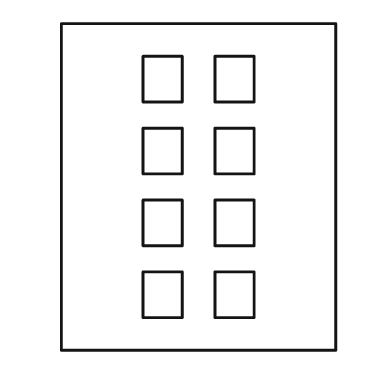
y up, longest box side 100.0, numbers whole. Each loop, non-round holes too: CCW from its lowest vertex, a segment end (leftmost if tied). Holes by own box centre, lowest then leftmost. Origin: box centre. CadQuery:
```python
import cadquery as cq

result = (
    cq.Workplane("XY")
    .moveTo(-42.0, -50.0)
    .lineTo(42.0, -50.0)
    .lineTo(42.0, 50.0)
    .lineTo(-42.0, 50.0)
    .close()
    .moveTo(-17.0, -40.0)
    .lineTo(-5.0, -40.0)
    .lineTo(-5.0, -26.0)
    .lineTo(-17.0, -26.0)
    .close()
    .moveTo(5.0, -40.0)
    .lineTo(17.0, -40.0)
    .lineTo(17.0, -26.0)
    .lineTo(5.0, -26.0)
    .close()
    .moveTo(-17.0, -18.0)
    .lineTo(-5.0, -18.0)
    .lineTo(-5.0, -4.0)
    .lineTo(-17.0, -4.0)
    .close()
    .moveTo(5.0, -18.0)
    .lineTo(17.0, -18.0)
    .lineTo(17.0, -4.0)
    .lineTo(5.0, -4.0)
    .close()
    .moveTo(-17.0, 4.0)
    .lineTo(-5.0, 4.0)
    .lineTo(-5.0, 18.0)
    .lineTo(-17.0, 18.0)
    .close()
    .moveTo(5.0, 4.0)
    .lineTo(17.0, 4.0)
    .lineTo(17.0, 18.0)
    .lineTo(5.0, 18.0)
    .close()
    .moveTo(-17.0, 26.0)
    .lineTo(-5.0, 26.0)
    .lineTo(-5.0, 40.0)
    .lineTo(-17.0, 40.0)
    .close()
    .moveTo(5.0, 26.0)
    .lineTo(17.0, 26.0)
    .lineTo(17.0, 40.0)
    .lineTo(5.0, 40.0)
    .close()
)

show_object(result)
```